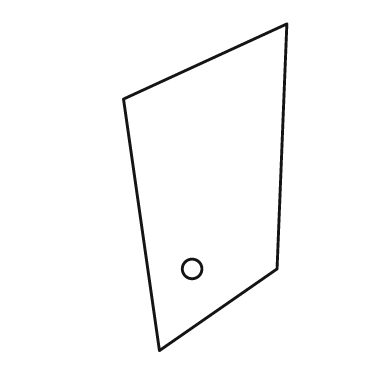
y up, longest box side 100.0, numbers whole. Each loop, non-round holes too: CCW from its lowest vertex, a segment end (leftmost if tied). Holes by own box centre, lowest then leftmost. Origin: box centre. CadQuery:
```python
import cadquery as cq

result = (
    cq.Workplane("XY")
    .moveTo(-14.0, -50.0)
    .lineTo(22.0, -25.0)
    .lineTo(25.0, 50.0)
    .lineTo(-25.0, 27.0)
    .close()
    .moveTo(-4.0, -25.0)
    .circle(3.0)
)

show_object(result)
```